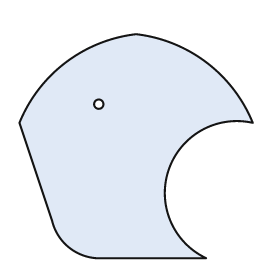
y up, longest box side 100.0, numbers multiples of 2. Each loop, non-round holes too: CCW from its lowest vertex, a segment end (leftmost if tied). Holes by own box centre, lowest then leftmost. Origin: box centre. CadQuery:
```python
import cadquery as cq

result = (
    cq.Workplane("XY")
    .moveTo(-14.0, -48.0)
    .lineTo(30.0, -48.0)
    .threePointArc((14.0, -10.0), (50.0, 10.0))
    .threePointArc((30.0, 36.0), (0.0, 48.0))
    .threePointArc((-30.0, 36.0), (-50.0, 10.0))
    .lineTo(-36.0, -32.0)
    .threePointArc((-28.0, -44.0), (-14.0, -48.0))
    .close()
    .moveTo(-16.0, 18.0)
    .circle(2.0)
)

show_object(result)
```